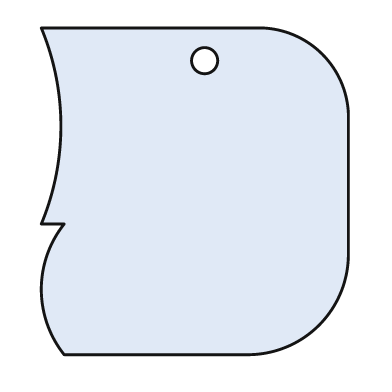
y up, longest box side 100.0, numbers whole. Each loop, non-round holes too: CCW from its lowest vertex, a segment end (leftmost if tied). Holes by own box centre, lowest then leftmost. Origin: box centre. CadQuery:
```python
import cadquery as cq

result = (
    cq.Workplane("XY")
    .moveTo(-40.0, -50.0)
    .lineTo(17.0, -50.0)
    .threePointArc((38.0, -41.0), (47.0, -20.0))
    .lineTo(47.0, 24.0)
    .threePointArc((39.0, 42.0), (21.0, 50.0))
    .lineTo(-47.0, 50.0)
    .threePointArc((-41.0, 20.0), (-47.0, -10.0))
    .lineTo(-40.0, -10.0)
    .threePointArc((-47.0, -30.0), (-40.0, -50.0))
    .close()
    .moveTo(3.0, 40.0)
    .circle(4.0)
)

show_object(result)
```